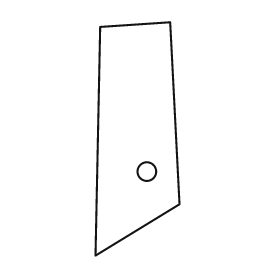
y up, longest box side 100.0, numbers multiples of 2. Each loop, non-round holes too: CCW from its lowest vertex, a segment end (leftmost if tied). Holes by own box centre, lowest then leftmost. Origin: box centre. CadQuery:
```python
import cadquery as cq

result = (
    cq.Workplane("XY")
    .moveTo(-18.0, -50.0)
    .lineTo(18.0, -28.0)
    .lineTo(14.0, 50.0)
    .lineTo(-16.0, 48.0)
    .close()
    .moveTo(4.0, -14.0)
    .circle(4.0)
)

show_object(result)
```